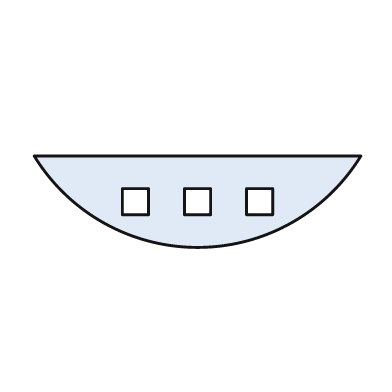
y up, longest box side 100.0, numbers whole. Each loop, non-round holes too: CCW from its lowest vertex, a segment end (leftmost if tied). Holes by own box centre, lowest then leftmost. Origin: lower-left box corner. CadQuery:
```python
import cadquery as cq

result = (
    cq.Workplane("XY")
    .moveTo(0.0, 28.0)
    .threePointArc((50.0, 0.0), (100.0, 28.0))
    .close()
    .moveTo(27.0, 10.0)
    .lineTo(35.0, 10.0)
    .lineTo(35.0, 18.0)
    .lineTo(27.0, 18.0)
    .close()
    .moveTo(46.0, 10.0)
    .lineTo(54.0, 10.0)
    .lineTo(54.0, 18.0)
    .lineTo(46.0, 18.0)
    .close()
    .moveTo(65.0, 10.0)
    .lineTo(73.0, 10.0)
    .lineTo(73.0, 18.0)
    .lineTo(65.0, 18.0)
    .close()
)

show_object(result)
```